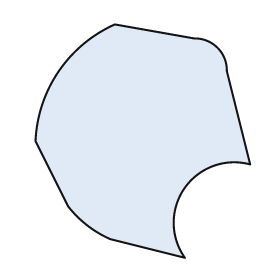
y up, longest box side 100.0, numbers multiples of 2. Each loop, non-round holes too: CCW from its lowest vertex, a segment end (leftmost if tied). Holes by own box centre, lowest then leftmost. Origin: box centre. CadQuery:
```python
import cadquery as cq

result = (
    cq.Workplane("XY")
    .moveTo(18.0, -50.0)
    .threePointArc((18.0, -20.0), (46.0, -10.0))
    .lineTo(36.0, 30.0)
    .threePointArc((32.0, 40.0), (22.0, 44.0))
    .lineTo(-12.0, 50.0)
    .threePointArc((-36.0, 30.0), (-46.0, 0.0))
    .lineTo(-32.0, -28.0)
    .threePointArc((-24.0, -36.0), (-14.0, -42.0))
    .close()
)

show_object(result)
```